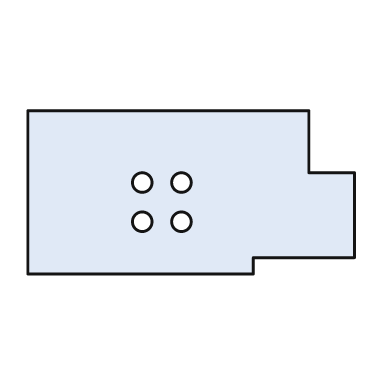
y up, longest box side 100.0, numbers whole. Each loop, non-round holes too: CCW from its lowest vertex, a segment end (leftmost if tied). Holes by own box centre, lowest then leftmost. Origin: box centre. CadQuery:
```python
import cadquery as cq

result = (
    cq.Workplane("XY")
    .moveTo(-50.0, -25.0)
    .lineTo(19.0, -25.0)
    .lineTo(19.0, -20.0)
    .lineTo(50.0, -20.0)
    .lineTo(50.0, 6.0)
    .lineTo(36.0, 6.0)
    .lineTo(36.0, 25.0)
    .lineTo(-50.0, 25.0)
    .close()
    .moveTo(-15.0, -9.0)
    .circle(3.0)
    .moveTo(-3.0, -9.0)
    .circle(3.0)
    .moveTo(-15.0, 3.0)
    .circle(3.0)
    .moveTo(-3.0, 3.0)
    .circle(3.0)
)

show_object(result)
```